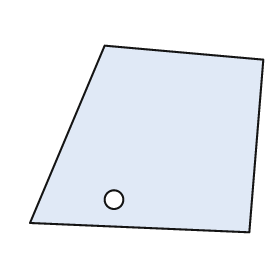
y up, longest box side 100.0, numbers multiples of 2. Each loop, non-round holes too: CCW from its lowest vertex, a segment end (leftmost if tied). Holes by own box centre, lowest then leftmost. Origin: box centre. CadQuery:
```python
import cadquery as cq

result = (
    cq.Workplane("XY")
    .moveTo(44.0, -40.0)
    .lineTo(50.0, 34.0)
    .lineTo(-18.0, 40.0)
    .lineTo(-50.0, -36.0)
    .close()
    .moveTo(-14.0, -26.0)
    .circle(4.0)
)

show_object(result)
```